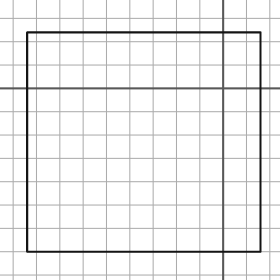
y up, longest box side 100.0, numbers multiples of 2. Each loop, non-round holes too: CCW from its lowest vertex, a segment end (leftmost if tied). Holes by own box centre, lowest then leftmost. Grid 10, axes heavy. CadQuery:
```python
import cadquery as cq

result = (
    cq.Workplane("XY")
    .moveTo(-84.0, -70.0)
    .lineTo(16.0, -70.0)
    .lineTo(16.0, 24.0)
    .lineTo(-84.0, 24.0)
    .close()
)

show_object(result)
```